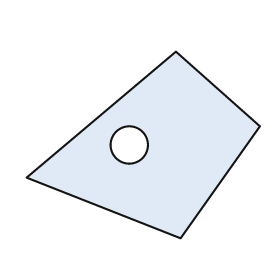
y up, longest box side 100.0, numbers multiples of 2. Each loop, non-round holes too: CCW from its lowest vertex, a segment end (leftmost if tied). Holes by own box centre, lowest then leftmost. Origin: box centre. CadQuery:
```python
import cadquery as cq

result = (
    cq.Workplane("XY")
    .moveTo(16.0, -40.0)
    .lineTo(50.0, 8.0)
    .lineTo(14.0, 40.0)
    .lineTo(-50.0, -14.0)
    .close()
    .moveTo(-6.0, 0.0)
    .circle(8.0)
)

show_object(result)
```